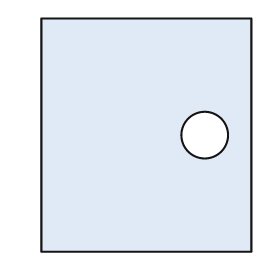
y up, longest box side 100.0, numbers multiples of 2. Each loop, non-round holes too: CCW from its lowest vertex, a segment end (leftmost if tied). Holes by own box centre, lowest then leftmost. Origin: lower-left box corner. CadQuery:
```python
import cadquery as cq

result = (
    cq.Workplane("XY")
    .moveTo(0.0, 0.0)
    .lineTo(90.0, 0.0)
    .lineTo(90.0, 100.0)
    .lineTo(0.0, 100.0)
    .close()
    .moveTo(70.0, 50.0)
    .circle(10.0)
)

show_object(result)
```